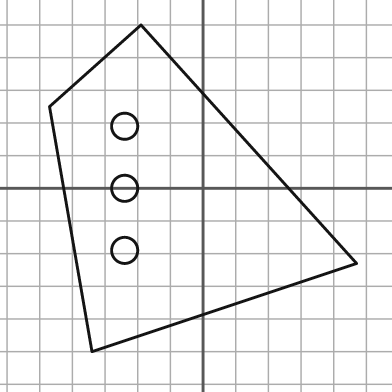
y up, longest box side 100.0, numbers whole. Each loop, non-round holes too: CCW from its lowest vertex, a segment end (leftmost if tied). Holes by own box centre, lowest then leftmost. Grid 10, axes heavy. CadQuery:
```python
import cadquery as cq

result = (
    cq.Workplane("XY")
    .moveTo(-34.0, -50.0)
    .lineTo(47.0, -23.0)
    .lineTo(-19.0, 50.0)
    .lineTo(-47.0, 25.0)
    .close()
    .moveTo(-24.0, -19.0)
    .circle(4.0)
    .moveTo(-24.0, 0.0)
    .circle(4.0)
    .moveTo(-24.0, 19.0)
    .circle(4.0)
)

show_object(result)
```